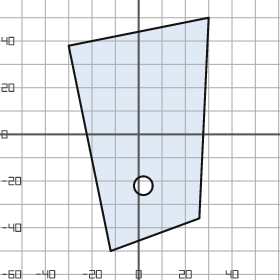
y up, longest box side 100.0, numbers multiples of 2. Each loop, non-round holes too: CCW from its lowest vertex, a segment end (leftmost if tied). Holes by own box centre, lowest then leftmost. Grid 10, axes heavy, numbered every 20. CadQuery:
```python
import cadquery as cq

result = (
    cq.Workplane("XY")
    .moveTo(-12.0, -50.0)
    .lineTo(26.0, -36.0)
    .lineTo(30.0, 50.0)
    .lineTo(-30.0, 38.0)
    .close()
    .moveTo(2.0, -22.0)
    .circle(4.0)
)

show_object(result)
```